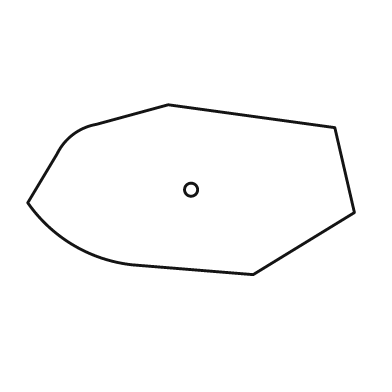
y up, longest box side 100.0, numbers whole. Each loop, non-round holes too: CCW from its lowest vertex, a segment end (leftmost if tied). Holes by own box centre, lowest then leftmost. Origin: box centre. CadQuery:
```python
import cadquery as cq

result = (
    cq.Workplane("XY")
    .moveTo(19.0, -26.0)
    .lineTo(50.0, -7.0)
    .lineTo(44.0, 19.0)
    .lineTo(-7.0, 26.0)
    .lineTo(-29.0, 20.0)
    .threePointArc((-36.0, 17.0), (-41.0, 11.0))
    .lineTo(-50.0, -4.0)
    .threePointArc((-36.0, -17.0), (-18.0, -23.0))
    .close()
    .moveTo(0.0, 0.0)
    .circle(2.0)
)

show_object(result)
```